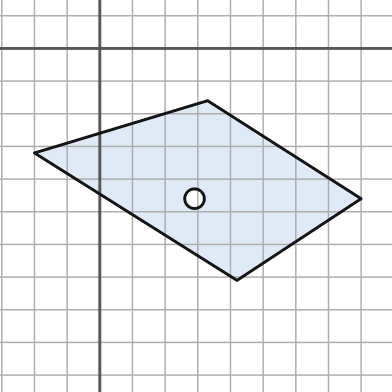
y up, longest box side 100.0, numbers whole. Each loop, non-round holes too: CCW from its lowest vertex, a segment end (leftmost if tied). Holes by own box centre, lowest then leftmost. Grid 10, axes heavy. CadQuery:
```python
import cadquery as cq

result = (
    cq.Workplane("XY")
    .moveTo(42.0, -71.0)
    .lineTo(80.0, -46.0)
    .lineTo(33.0, -16.0)
    .lineTo(-20.0, -32.0)
    .close()
    .moveTo(29.0, -46.0)
    .circle(3.0)
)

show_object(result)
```